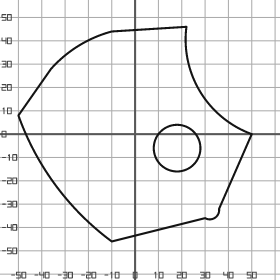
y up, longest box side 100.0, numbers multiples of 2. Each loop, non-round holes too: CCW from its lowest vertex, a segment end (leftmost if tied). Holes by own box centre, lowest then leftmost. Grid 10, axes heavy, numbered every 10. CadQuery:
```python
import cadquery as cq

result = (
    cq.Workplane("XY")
    .moveTo(-10.0, -46.0)
    .lineTo(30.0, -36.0)
    .threePointArc((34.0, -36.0), (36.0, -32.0))
    .lineTo(50.0, 0.0)
    .threePointArc((28.0, 18.0), (22.0, 46.0))
    .lineTo(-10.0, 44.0)
    .threePointArc((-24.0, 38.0), (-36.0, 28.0))
    .lineTo(-50.0, 8.0)
    .threePointArc((-34.0, -22.0), (-10.0, -46.0))
    .close()
    .moveTo(18.0, -6.0)
    .circle(10.0)
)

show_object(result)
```